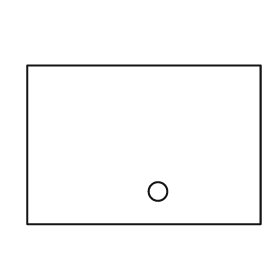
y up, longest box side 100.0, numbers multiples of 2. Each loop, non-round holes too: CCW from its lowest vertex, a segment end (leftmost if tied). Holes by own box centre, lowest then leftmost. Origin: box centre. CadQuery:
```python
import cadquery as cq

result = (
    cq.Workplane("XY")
    .moveTo(-50.0, -34.0)
    .lineTo(50.0, -34.0)
    .lineTo(50.0, 34.0)
    .lineTo(-50.0, 34.0)
    .close()
    .moveTo(6.0, -20.0)
    .circle(4.0)
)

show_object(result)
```